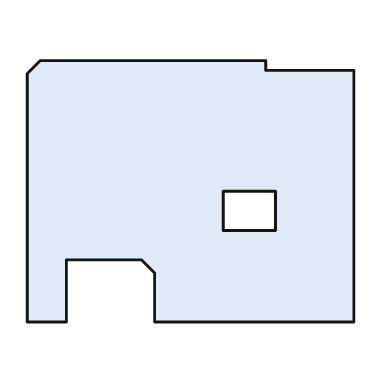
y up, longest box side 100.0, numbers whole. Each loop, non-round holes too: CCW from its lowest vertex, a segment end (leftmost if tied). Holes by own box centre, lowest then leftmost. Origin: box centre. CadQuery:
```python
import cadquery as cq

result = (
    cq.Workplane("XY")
    .moveTo(-50.0, -40.0)
    .lineTo(-38.0, -40.0)
    .lineTo(-38.0, -21.0)
    .lineTo(-15.0, -21.0)
    .lineTo(-11.0, -25.0)
    .lineTo(-11.0, -40.0)
    .lineTo(50.0, -40.0)
    .lineTo(50.0, 37.0)
    .lineTo(23.0, 37.0)
    .lineTo(23.0, 40.0)
    .lineTo(-46.0, 40.0)
    .lineTo(-50.0, 36.0)
    .close()
    .moveTo(10.0, -12.0)
    .lineTo(26.0, -12.0)
    .lineTo(26.0, 0.0)
    .lineTo(10.0, 0.0)
    .close()
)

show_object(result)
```